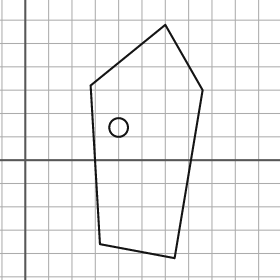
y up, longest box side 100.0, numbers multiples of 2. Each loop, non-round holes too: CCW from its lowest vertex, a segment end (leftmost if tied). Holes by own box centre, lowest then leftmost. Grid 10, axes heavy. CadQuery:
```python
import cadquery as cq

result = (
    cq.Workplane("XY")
    .moveTo(64.0, -42.0)
    .lineTo(76.0, 30.0)
    .lineTo(60.0, 58.0)
    .lineTo(28.0, 32.0)
    .lineTo(32.0, -36.0)
    .close()
    .moveTo(40.0, 14.0)
    .circle(4.0)
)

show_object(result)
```